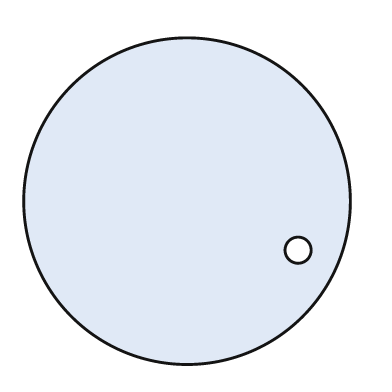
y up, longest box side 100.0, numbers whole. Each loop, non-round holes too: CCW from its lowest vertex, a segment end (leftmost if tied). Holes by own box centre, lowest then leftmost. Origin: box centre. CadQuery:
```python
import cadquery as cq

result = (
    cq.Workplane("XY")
    .moveTo(0.0, 0.0)
    .circle(50.0)
    .moveTo(34.0, -15.0)
    .circle(4.0)
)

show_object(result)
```